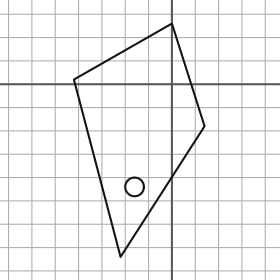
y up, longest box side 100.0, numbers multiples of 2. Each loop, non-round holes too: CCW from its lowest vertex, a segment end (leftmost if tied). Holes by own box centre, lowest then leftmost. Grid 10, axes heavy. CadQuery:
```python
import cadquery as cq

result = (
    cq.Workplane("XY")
    .moveTo(-22.0, -74.0)
    .lineTo(14.0, -18.0)
    .lineTo(0.0, 26.0)
    .lineTo(-42.0, 2.0)
    .close()
    .moveTo(-16.0, -44.0)
    .circle(4.0)
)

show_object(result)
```